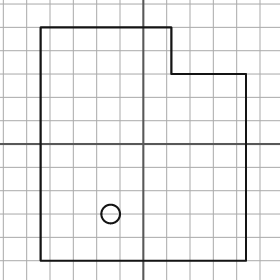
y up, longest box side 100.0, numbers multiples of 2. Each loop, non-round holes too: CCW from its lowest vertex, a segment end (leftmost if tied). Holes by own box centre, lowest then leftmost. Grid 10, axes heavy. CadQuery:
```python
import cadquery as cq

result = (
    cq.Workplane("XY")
    .moveTo(-44.0, -50.0)
    .lineTo(44.0, -50.0)
    .lineTo(44.0, 30.0)
    .lineTo(12.0, 30.0)
    .lineTo(12.0, 50.0)
    .lineTo(-44.0, 50.0)
    .close()
    .moveTo(-14.0, -30.0)
    .circle(4.0)
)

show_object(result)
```